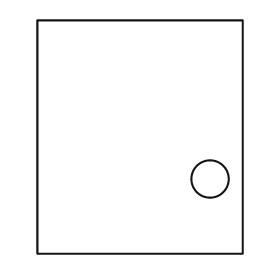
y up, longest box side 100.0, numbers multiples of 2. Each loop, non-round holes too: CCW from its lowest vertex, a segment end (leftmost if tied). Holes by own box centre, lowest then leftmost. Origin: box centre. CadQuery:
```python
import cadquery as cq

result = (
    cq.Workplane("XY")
    .moveTo(-44.0, -50.0)
    .lineTo(44.0, -50.0)
    .lineTo(44.0, 50.0)
    .lineTo(-44.0, 50.0)
    .close()
    .moveTo(30.0, -18.0)
    .circle(8.0)
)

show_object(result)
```